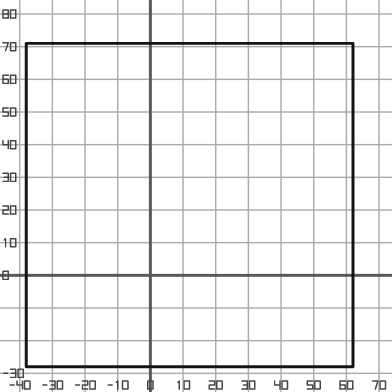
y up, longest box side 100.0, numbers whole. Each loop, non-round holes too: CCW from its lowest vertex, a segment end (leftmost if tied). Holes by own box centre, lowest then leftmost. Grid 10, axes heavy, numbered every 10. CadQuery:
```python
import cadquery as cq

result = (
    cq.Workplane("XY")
    .moveTo(-38.0, -28.0)
    .lineTo(62.0, -28.0)
    .lineTo(62.0, 71.0)
    .lineTo(-38.0, 71.0)
    .close()
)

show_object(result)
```